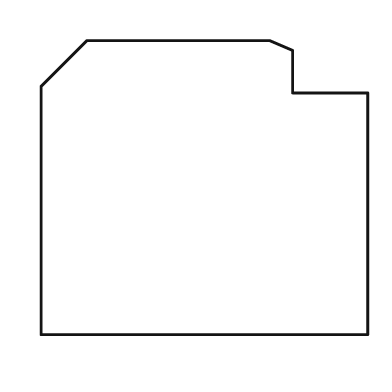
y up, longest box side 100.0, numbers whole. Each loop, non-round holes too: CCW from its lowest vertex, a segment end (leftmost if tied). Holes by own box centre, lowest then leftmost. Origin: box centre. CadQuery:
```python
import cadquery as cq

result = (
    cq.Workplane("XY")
    .moveTo(-50.0, -45.0)
    .lineTo(50.0, -45.0)
    .lineTo(50.0, 29.0)
    .lineTo(27.0, 29.0)
    .lineTo(27.0, 42.0)
    .lineTo(20.0, 45.0)
    .lineTo(-36.0, 45.0)
    .lineTo(-50.0, 31.0)
    .close()
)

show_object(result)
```